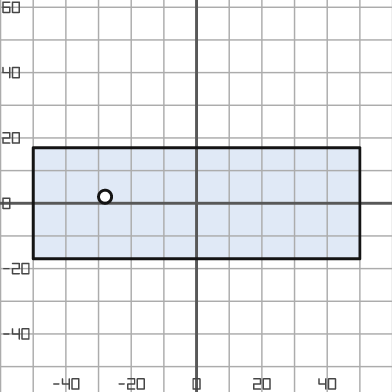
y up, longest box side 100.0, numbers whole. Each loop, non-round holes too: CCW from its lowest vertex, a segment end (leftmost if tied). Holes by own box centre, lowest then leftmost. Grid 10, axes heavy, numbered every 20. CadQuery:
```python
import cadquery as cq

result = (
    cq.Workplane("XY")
    .moveTo(-50.0, -17.0)
    .lineTo(50.0, -17.0)
    .lineTo(50.0, 17.0)
    .lineTo(-50.0, 17.0)
    .close()
    .moveTo(-28.0, 2.0)
    .circle(2.0)
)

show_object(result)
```